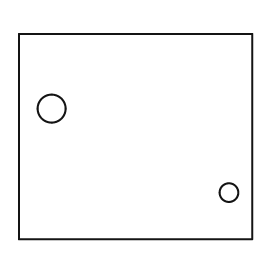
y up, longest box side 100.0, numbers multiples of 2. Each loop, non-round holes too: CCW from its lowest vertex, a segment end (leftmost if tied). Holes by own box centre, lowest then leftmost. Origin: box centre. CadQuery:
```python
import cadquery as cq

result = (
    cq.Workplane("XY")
    .moveTo(-50.0, -44.0)
    .lineTo(50.0, -44.0)
    .lineTo(50.0, 44.0)
    .lineTo(-50.0, 44.0)
    .close()
    .moveTo(40.0, -24.0)
    .circle(4.0)
    .moveTo(-36.0, 12.0)
    .circle(6.0)
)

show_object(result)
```